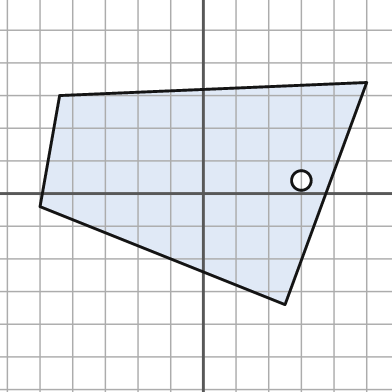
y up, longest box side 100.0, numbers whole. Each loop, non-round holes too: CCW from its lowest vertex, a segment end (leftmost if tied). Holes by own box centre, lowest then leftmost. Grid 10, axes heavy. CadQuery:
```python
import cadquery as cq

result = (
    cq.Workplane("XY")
    .moveTo(25.0, -34.0)
    .lineTo(50.0, 34.0)
    .lineTo(-44.0, 30.0)
    .lineTo(-50.0, -4.0)
    .close()
    .moveTo(30.0, 4.0)
    .circle(3.0)
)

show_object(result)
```